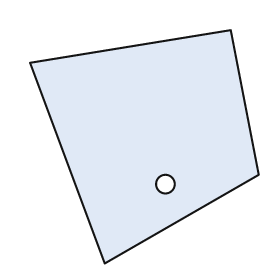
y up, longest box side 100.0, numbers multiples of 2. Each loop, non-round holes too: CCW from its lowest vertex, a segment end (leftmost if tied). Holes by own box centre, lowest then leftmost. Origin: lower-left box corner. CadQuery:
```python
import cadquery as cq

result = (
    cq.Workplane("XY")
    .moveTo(32.0, 0.0)
    .lineTo(98.0, 38.0)
    .lineTo(86.0, 100.0)
    .lineTo(0.0, 86.0)
    .close()
    .moveTo(58.0, 34.0)
    .circle(4.0)
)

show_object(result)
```